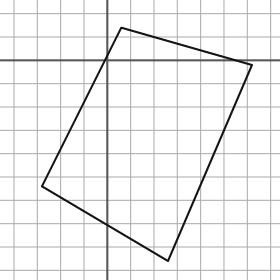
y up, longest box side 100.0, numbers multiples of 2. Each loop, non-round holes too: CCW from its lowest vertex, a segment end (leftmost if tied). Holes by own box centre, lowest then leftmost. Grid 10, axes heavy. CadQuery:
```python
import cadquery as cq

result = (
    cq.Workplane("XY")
    .moveTo(26.0, -86.0)
    .lineTo(62.0, -2.0)
    .lineTo(6.0, 14.0)
    .lineTo(-28.0, -54.0)
    .close()
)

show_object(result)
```